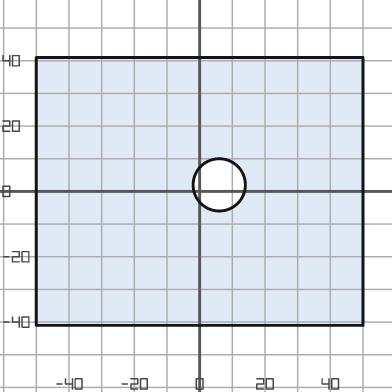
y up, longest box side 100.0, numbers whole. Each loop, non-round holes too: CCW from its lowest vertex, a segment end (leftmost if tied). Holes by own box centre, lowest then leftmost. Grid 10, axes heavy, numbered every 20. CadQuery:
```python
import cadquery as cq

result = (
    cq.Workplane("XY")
    .moveTo(-50.0, -41.0)
    .lineTo(50.0, -41.0)
    .lineTo(50.0, 41.0)
    .lineTo(-50.0, 41.0)
    .close()
    .moveTo(6.0, 2.0)
    .circle(8.0)
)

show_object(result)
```